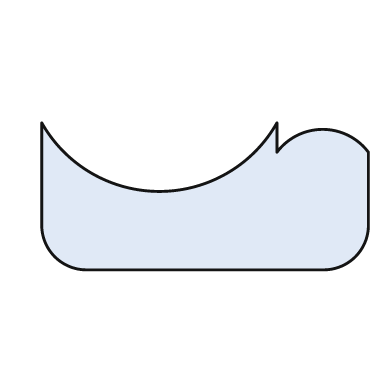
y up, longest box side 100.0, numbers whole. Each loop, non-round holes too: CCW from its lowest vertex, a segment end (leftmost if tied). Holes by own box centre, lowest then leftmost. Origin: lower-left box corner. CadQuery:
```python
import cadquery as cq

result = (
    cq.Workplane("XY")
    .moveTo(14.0, 0.0)
    .lineTo(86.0, 0.0)
    .threePointArc((96.0, 4.0), (100.0, 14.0))
    .lineTo(100.0, 36.0)
    .threePointArc((86.0, 43.0), (72.0, 36.0))
    .lineTo(72.0, 45.0)
    .threePointArc((36.0, 24.0), (0.0, 45.0))
    .lineTo(0.0, 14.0)
    .threePointArc((4.0, 4.0), (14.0, 0.0))
    .close()
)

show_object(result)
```